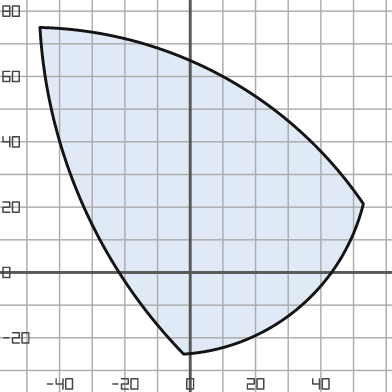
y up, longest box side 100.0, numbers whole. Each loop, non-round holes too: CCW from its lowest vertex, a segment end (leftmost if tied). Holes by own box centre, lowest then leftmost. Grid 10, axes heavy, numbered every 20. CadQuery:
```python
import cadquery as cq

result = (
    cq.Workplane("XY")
    .moveTo(-2.0, -25.0)
    .threePointArc((33.0, -11.0), (53.0, 21.0))
    .threePointArc((10.0, 60.0), (-46.0, 75.0))
    .threePointArc((-33.0, 21.0), (-2.0, -25.0))
    .close()
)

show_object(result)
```